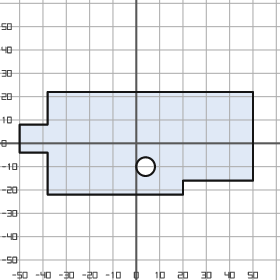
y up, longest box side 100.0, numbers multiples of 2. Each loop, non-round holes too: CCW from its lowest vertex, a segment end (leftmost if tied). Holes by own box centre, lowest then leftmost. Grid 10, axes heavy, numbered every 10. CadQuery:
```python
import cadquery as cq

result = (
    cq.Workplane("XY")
    .moveTo(-38.0, -22.0)
    .lineTo(20.0, -22.0)
    .lineTo(20.0, -16.0)
    .lineTo(50.0, -16.0)
    .lineTo(50.0, 22.0)
    .lineTo(-38.0, 22.0)
    .lineTo(-38.0, 8.0)
    .lineTo(-50.0, 8.0)
    .lineTo(-50.0, -4.0)
    .lineTo(-38.0, -4.0)
    .close()
    .moveTo(4.0, -10.0)
    .circle(4.0)
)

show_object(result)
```